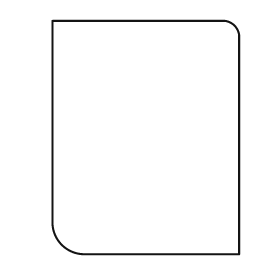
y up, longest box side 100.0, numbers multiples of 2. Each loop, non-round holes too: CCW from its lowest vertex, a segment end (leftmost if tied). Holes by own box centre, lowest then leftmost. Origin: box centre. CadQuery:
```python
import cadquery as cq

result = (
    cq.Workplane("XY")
    .moveTo(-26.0, -50.0)
    .lineTo(40.0, -50.0)
    .lineTo(40.0, 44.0)
    .threePointArc((38.0, 48.0), (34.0, 50.0))
    .lineTo(-40.0, 50.0)
    .lineTo(-40.0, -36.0)
    .threePointArc((-36.0, -46.0), (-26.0, -50.0))
    .close()
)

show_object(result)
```